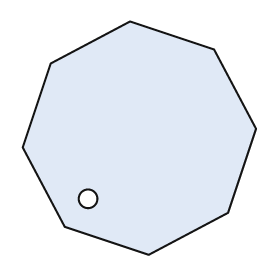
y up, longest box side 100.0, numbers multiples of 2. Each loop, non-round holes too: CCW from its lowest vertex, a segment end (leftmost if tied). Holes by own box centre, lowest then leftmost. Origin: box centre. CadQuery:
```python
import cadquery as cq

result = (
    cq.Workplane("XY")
    .moveTo(4.0, -50.0)
    .lineTo(38.0, -32.0)
    .lineTo(50.0, 4.0)
    .lineTo(32.0, 38.0)
    .lineTo(-4.0, 50.0)
    .lineTo(-38.0, 32.0)
    .lineTo(-50.0, -4.0)
    .lineTo(-32.0, -38.0)
    .close()
    .moveTo(-22.0, -26.0)
    .circle(4.0)
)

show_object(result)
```